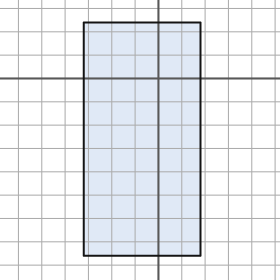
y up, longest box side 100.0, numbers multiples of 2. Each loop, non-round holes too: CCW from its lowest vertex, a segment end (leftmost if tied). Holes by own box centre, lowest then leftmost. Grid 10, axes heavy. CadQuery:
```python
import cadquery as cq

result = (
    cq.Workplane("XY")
    .moveTo(-32.0, -76.0)
    .lineTo(18.0, -76.0)
    .lineTo(18.0, 24.0)
    .lineTo(-32.0, 24.0)
    .close()
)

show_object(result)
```